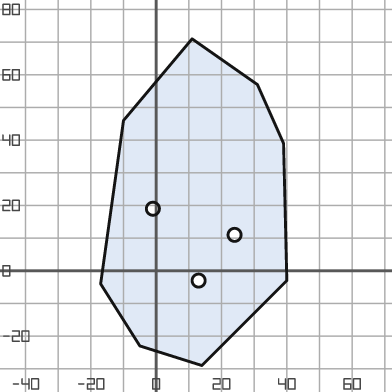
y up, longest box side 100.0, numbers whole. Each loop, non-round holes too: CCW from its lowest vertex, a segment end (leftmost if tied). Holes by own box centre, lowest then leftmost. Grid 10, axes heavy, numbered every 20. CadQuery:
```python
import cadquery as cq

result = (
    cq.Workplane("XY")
    .moveTo(14.0, -29.0)
    .lineTo(40.0, -3.0)
    .lineTo(39.0, 39.0)
    .lineTo(31.0, 57.0)
    .lineTo(11.0, 71.0)
    .lineTo(-10.0, 46.0)
    .lineTo(-17.0, -4.0)
    .lineTo(-5.0, -23.0)
    .close()
    .moveTo(13.0, -3.0)
    .circle(2.0)
    .moveTo(24.0, 11.0)
    .circle(2.0)
    .moveTo(-1.0, 19.0)
    .circle(2.0)
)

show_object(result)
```